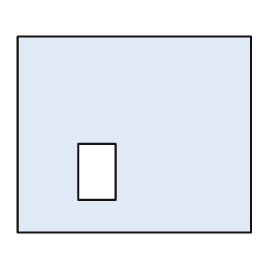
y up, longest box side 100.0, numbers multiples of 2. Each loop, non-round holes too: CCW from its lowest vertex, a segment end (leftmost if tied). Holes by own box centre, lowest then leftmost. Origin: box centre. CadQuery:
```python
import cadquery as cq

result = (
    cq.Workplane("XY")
    .moveTo(-50.0, -42.0)
    .lineTo(50.0, -42.0)
    .lineTo(50.0, 42.0)
    .lineTo(-50.0, 42.0)
    .close()
    .moveTo(-24.0, -28.0)
    .lineTo(-8.0, -28.0)
    .lineTo(-8.0, -4.0)
    .lineTo(-24.0, -4.0)
    .close()
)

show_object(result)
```